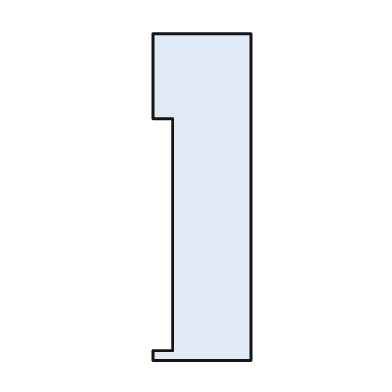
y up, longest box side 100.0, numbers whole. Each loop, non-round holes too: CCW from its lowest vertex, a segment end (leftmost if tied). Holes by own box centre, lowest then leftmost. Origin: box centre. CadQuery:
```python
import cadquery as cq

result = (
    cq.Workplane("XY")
    .moveTo(-15.0, -50.0)
    .lineTo(15.0, -50.0)
    .lineTo(15.0, 50.0)
    .lineTo(-15.0, 50.0)
    .lineTo(-15.0, 24.0)
    .lineTo(-9.0, 24.0)
    .lineTo(-9.0, -47.0)
    .lineTo(-15.0, -47.0)
    .close()
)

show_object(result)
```